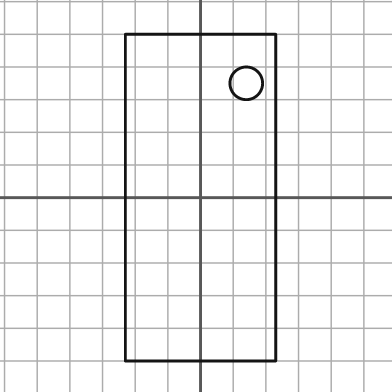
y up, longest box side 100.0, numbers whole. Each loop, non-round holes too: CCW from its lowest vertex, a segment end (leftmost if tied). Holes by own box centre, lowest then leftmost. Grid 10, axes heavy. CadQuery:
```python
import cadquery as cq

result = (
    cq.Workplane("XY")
    .moveTo(-23.0, -50.0)
    .lineTo(23.0, -50.0)
    .lineTo(23.0, 50.0)
    .lineTo(-23.0, 50.0)
    .close()
    .moveTo(14.0, 35.0)
    .circle(5.0)
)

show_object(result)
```